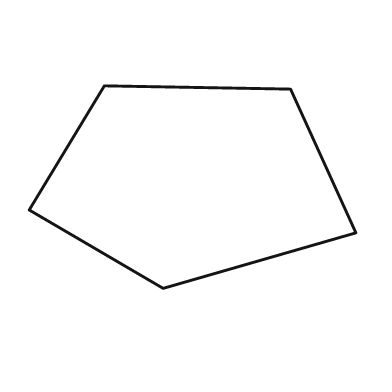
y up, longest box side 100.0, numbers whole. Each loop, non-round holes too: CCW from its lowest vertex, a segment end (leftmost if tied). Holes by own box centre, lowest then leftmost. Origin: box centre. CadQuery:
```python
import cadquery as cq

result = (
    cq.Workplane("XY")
    .moveTo(-9.0, -31.0)
    .lineTo(50.0, -14.0)
    .lineTo(30.0, 30.0)
    .lineTo(-27.0, 31.0)
    .lineTo(-50.0, -7.0)
    .close()
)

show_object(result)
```